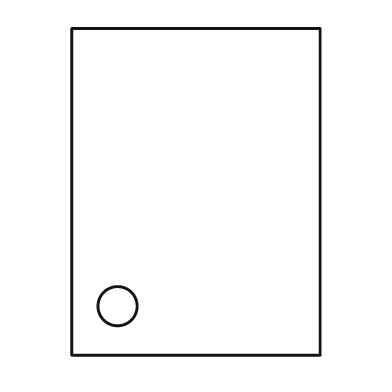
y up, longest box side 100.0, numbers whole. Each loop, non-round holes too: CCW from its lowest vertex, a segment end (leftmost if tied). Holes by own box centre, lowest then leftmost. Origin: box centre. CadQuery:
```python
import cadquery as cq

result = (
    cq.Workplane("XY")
    .moveTo(-38.0, -50.0)
    .lineTo(38.0, -50.0)
    .lineTo(38.0, 50.0)
    .lineTo(-38.0, 50.0)
    .close()
    .moveTo(-24.0, -35.0)
    .circle(6.0)
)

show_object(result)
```